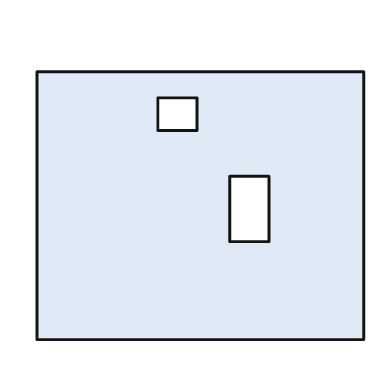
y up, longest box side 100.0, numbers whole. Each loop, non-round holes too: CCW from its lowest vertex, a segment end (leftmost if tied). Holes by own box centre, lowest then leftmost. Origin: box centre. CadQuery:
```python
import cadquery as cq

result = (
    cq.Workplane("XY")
    .moveTo(-50.0, -41.0)
    .lineTo(50.0, -41.0)
    .lineTo(50.0, 41.0)
    .lineTo(-50.0, 41.0)
    .close()
    .moveTo(9.0, -11.0)
    .lineTo(21.0, -11.0)
    .lineTo(21.0, 9.0)
    .lineTo(9.0, 9.0)
    .close()
    .moveTo(-13.0, 23.0)
    .lineTo(-1.0, 23.0)
    .lineTo(-1.0, 33.0)
    .lineTo(-13.0, 33.0)
    .close()
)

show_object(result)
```